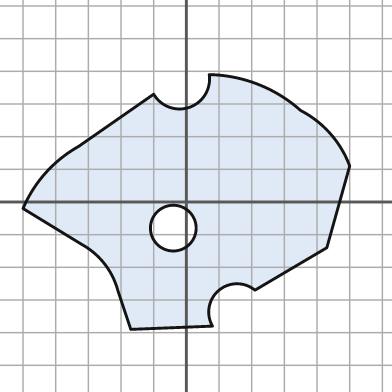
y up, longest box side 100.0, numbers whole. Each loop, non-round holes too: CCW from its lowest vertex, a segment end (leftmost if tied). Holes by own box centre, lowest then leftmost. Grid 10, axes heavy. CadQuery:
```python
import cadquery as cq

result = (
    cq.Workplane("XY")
    .moveTo(-17.0, -39.0)
    .lineTo(8.0, -38.0)
    .threePointArc((10.0, -27.0), (21.0, -27.0))
    .lineTo(43.0, -14.0)
    .lineTo(50.0, 11.0)
    .threePointArc((44.0, 21.0), (35.0, 28.0))
    .threePointArc((22.0, 36.0), (7.0, 39.0))
    .threePointArc((1.0, 29.0), (-10.0, 33.0))
    .lineTo(-33.0, 17.0)
    .threePointArc((-43.0, 9.0), (-50.0, -2.0))
    .lineTo(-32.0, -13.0)
    .threePointArc((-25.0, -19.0), (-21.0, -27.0))
    .close()
    .moveTo(-4.0, -8.0)
    .circle(7.0)
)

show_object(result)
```